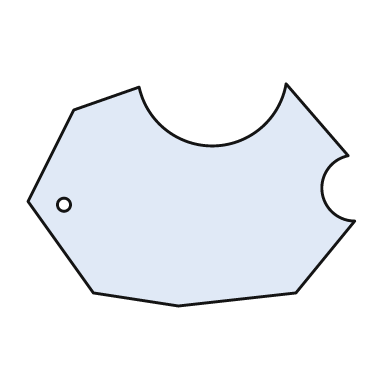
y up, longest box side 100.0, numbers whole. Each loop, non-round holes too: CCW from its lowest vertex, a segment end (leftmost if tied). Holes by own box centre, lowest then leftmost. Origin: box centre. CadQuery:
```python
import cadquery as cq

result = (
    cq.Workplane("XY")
    .moveTo(-4.0, -34.0)
    .lineTo(32.0, -30.0)
    .lineTo(50.0, -8.0)
    .threePointArc((40.0, 1.0), (48.0, 12.0))
    .lineTo(29.0, 34.0)
    .threePointArc((7.0, 15.0), (-16.0, 33.0))
    .lineTo(-36.0, 26.0)
    .lineTo(-50.0, -2.0)
    .lineTo(-30.0, -30.0)
    .close()
    .moveTo(-39.0, -3.0)
    .circle(2.0)
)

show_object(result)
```